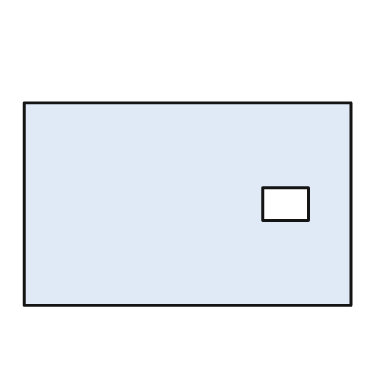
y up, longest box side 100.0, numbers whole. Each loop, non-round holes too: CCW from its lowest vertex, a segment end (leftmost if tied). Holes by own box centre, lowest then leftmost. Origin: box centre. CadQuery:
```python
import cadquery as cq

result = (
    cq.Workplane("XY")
    .moveTo(-50.0, -31.0)
    .lineTo(50.0, -31.0)
    .lineTo(50.0, 31.0)
    .lineTo(-50.0, 31.0)
    .close()
    .moveTo(23.0, -5.0)
    .lineTo(37.0, -5.0)
    .lineTo(37.0, 5.0)
    .lineTo(23.0, 5.0)
    .close()
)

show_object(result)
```